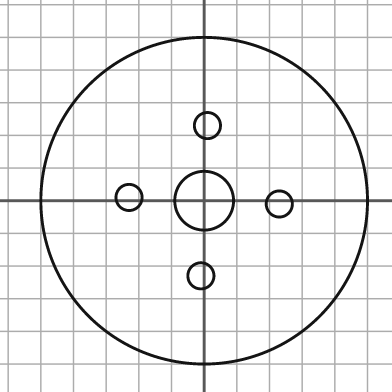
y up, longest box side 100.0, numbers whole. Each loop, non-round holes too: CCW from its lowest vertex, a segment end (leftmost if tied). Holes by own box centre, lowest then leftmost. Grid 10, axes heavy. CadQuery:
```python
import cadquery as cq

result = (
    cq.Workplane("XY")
    .moveTo(0.0, 0.0)
    .circle(50.0)
    .moveTo(-1.0, -23.0)
    .circle(4.0)
    .moveTo(23.0, -1.0)
    .circle(4.0)
    .moveTo(0.0, 0.0)
    .circle(9.0)
    .moveTo(-23.0, 1.0)
    .circle(4.0)
    .moveTo(1.0, 23.0)
    .circle(4.0)
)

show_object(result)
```